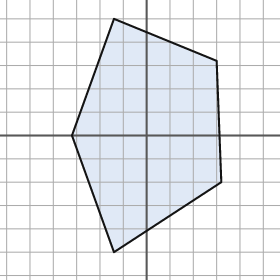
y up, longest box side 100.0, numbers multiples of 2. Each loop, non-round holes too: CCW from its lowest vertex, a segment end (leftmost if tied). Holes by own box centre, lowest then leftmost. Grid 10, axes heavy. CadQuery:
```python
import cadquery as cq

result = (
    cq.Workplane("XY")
    .moveTo(-14.0, -50.0)
    .lineTo(32.0, -20.0)
    .lineTo(30.0, 32.0)
    .lineTo(-14.0, 50.0)
    .lineTo(-32.0, 0.0)
    .close()
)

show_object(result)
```